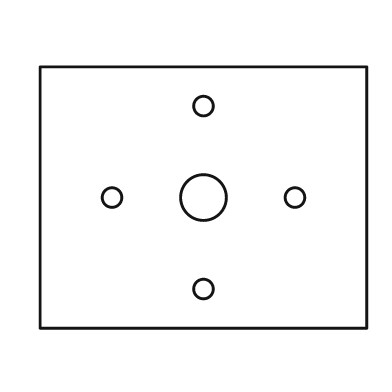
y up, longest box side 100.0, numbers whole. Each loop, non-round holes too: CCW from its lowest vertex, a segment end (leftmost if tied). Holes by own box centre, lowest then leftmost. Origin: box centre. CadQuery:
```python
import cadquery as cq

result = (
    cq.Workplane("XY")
    .moveTo(-50.0, -40.0)
    .lineTo(50.0, -40.0)
    .lineTo(50.0, 40.0)
    .lineTo(-50.0, 40.0)
    .close()
    .moveTo(0.0, -28.0)
    .circle(3.0)
    .moveTo(-28.0, 0.0)
    .circle(3.0)
    .moveTo(0.0, 0.0)
    .circle(7.0)
    .moveTo(28.0, 0.0)
    .circle(3.0)
    .moveTo(0.0, 28.0)
    .circle(3.0)
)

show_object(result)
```